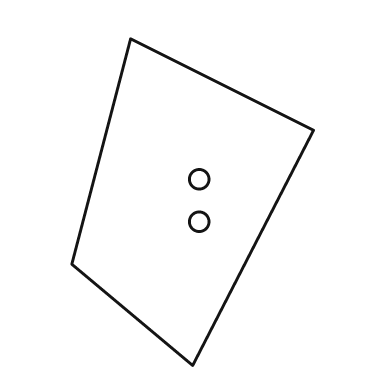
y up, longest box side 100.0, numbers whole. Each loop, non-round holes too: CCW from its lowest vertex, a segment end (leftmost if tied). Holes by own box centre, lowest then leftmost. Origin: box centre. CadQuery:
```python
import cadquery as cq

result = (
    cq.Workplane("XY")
    .moveTo(0.0, -50.0)
    .lineTo(37.0, 22.0)
    .lineTo(-19.0, 50.0)
    .lineTo(-37.0, -19.0)
    .close()
    .moveTo(2.0, -6.0)
    .circle(3.0)
    .moveTo(2.0, 7.0)
    .circle(3.0)
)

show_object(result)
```